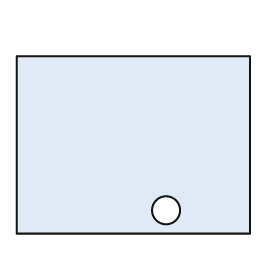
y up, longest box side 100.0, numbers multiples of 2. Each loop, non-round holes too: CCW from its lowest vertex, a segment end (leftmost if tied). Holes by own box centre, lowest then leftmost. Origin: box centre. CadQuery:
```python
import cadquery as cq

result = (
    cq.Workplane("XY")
    .moveTo(-50.0, -38.0)
    .lineTo(50.0, -38.0)
    .lineTo(50.0, 38.0)
    .lineTo(-50.0, 38.0)
    .close()
    .moveTo(14.0, -28.0)
    .circle(6.0)
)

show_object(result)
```